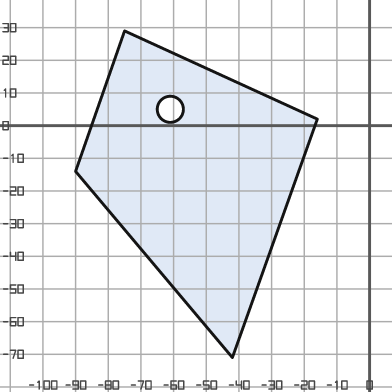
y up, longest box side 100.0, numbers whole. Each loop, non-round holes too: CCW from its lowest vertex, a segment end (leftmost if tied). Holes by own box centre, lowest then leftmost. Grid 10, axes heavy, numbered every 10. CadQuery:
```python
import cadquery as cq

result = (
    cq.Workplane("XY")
    .moveTo(-42.0, -71.0)
    .lineTo(-16.0, 2.0)
    .lineTo(-75.0, 29.0)
    .lineTo(-90.0, -14.0)
    .close()
    .moveTo(-61.0, 5.0)
    .circle(4.0)
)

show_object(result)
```